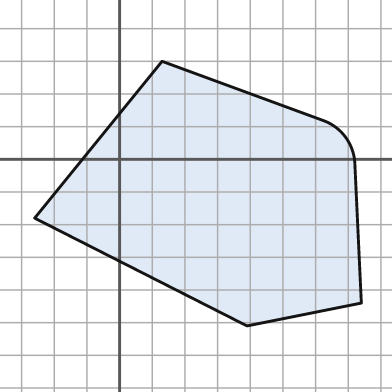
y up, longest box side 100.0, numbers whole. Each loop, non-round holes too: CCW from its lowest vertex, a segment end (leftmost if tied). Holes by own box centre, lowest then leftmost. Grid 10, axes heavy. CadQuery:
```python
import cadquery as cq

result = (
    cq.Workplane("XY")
    .moveTo(39.0, -51.0)
    .lineTo(74.0, -44.0)
    .lineTo(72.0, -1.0)
    .threePointArc((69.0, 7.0), (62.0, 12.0))
    .lineTo(13.0, 30.0)
    .lineTo(-26.0, -18.0)
    .close()
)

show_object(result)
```